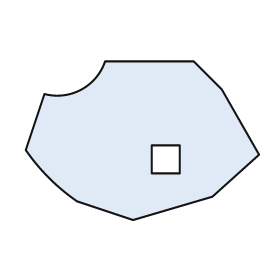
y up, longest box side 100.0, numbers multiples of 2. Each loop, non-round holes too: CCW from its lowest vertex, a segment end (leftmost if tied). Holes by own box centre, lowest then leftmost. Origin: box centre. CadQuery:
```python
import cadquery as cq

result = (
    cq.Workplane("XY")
    .moveTo(-4.0, -34.0)
    .lineTo(30.0, -24.0)
    .lineTo(50.0, -6.0)
    .lineTo(34.0, 22.0)
    .lineTo(22.0, 34.0)
    .lineTo(-16.0, 34.0)
    .threePointArc((-26.0, 22.0), (-42.0, 20.0))
    .lineTo(-50.0, -4.0)
    .threePointArc((-40.0, -16.0), (-28.0, -26.0))
    .close()
    .moveTo(4.0, -14.0)
    .lineTo(16.0, -14.0)
    .lineTo(16.0, -2.0)
    .lineTo(4.0, -2.0)
    .close()
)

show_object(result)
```